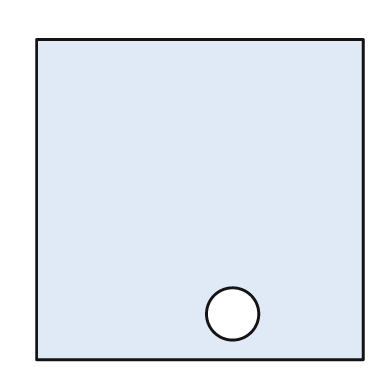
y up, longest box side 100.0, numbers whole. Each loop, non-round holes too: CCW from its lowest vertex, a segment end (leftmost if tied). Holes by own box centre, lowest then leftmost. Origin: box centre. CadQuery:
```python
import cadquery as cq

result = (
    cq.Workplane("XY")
    .moveTo(-50.0, -49.0)
    .lineTo(50.0, -49.0)
    .lineTo(50.0, 49.0)
    .lineTo(-50.0, 49.0)
    .close()
    .moveTo(10.0, -35.0)
    .circle(8.0)
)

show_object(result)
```